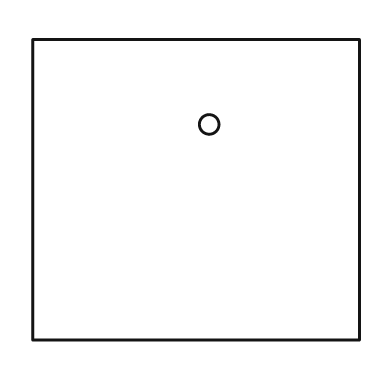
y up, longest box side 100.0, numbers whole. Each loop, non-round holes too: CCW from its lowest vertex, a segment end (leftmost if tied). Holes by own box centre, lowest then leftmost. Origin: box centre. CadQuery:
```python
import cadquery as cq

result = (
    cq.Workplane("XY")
    .moveTo(-50.0, -46.0)
    .lineTo(50.0, -46.0)
    .lineTo(50.0, 46.0)
    .lineTo(-50.0, 46.0)
    .close()
    .moveTo(4.0, 20.0)
    .circle(3.0)
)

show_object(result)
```